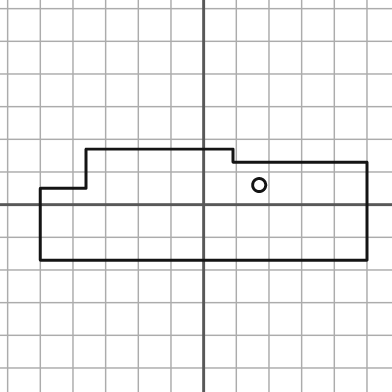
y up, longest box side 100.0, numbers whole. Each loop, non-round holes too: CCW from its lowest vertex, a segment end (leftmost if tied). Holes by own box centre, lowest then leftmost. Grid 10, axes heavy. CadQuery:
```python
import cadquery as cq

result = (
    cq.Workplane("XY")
    .moveTo(-50.0, -17.0)
    .lineTo(50.0, -17.0)
    .lineTo(50.0, 13.0)
    .lineTo(9.0, 13.0)
    .lineTo(9.0, 17.0)
    .lineTo(-36.0, 17.0)
    .lineTo(-36.0, 5.0)
    .lineTo(-50.0, 5.0)
    .close()
    .moveTo(17.0, 6.0)
    .circle(2.0)
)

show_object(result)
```